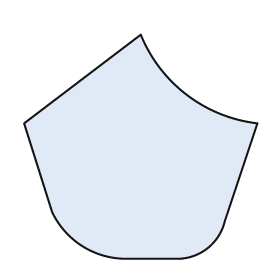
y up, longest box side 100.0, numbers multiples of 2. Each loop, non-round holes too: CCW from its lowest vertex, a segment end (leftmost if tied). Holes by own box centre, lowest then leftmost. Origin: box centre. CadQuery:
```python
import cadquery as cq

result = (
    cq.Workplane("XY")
    .moveTo(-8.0, -48.0)
    .lineTo(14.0, -48.0)
    .threePointArc((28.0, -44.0), (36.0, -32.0))
    .lineTo(50.0, 10.0)
    .threePointArc((20.0, 22.0), (0.0, 48.0))
    .lineTo(-50.0, 10.0)
    .lineTo(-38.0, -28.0)
    .threePointArc((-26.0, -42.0), (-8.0, -48.0))
    .close()
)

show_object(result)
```